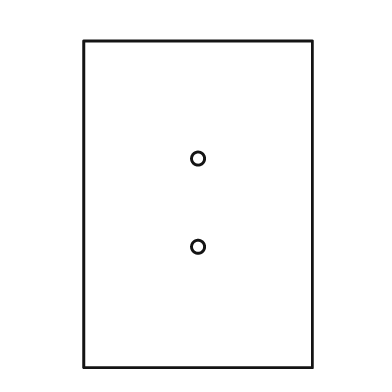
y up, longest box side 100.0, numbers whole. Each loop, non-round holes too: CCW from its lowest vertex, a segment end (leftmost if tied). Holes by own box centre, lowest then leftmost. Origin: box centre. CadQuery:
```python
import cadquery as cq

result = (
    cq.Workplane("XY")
    .moveTo(-35.0, -50.0)
    .lineTo(35.0, -50.0)
    .lineTo(35.0, 50.0)
    .lineTo(-35.0, 50.0)
    .close()
    .moveTo(0.0, -13.0)
    .circle(2.0)
    .moveTo(0.0, 14.0)
    .circle(2.0)
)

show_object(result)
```